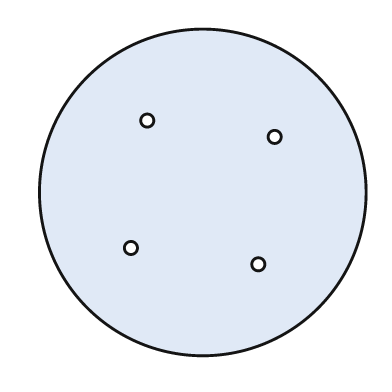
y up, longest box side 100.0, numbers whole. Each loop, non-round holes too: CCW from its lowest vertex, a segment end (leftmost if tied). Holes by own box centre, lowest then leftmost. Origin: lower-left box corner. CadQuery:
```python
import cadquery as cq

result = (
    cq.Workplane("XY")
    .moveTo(50.0, 50.0)
    .circle(50.0)
    .moveTo(67.0, 28.0)
    .circle(2.0)
    .moveTo(28.0, 33.0)
    .circle(2.0)
    .moveTo(72.0, 67.0)
    .circle(2.0)
    .moveTo(33.0, 72.0)
    .circle(2.0)
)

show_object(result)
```